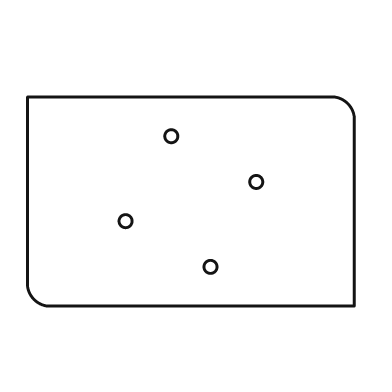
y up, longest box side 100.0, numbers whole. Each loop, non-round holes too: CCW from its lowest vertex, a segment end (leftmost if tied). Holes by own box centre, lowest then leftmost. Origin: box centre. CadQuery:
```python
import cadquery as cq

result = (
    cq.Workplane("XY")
    .moveTo(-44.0, -32.0)
    .lineTo(50.0, -32.0)
    .lineTo(50.0, 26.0)
    .threePointArc((48.0, 30.0), (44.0, 32.0))
    .lineTo(-50.0, 32.0)
    .lineTo(-50.0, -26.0)
    .threePointArc((-48.0, -30.0), (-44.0, -32.0))
    .close()
    .moveTo(6.0, -20.0)
    .circle(2.0)
    .moveTo(-20.0, -6.0)
    .circle(2.0)
    .moveTo(20.0, 6.0)
    .circle(2.0)
    .moveTo(-6.0, 20.0)
    .circle(2.0)
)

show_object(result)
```